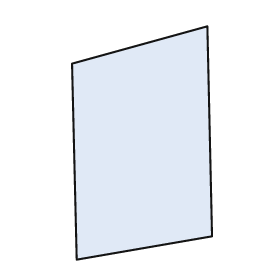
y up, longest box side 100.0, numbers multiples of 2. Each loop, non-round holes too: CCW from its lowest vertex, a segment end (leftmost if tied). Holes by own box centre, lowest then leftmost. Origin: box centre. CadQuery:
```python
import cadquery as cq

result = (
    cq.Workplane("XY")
    .moveTo(-28.0, -50.0)
    .lineTo(30.0, -40.0)
    .lineTo(28.0, 50.0)
    .lineTo(-30.0, 34.0)
    .close()
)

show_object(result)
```